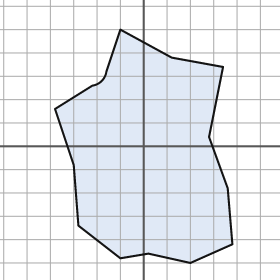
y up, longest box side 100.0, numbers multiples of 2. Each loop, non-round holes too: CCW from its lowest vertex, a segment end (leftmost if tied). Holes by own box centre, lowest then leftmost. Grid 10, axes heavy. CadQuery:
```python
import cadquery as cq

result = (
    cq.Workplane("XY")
    .moveTo(20.0, -50.0)
    .lineTo(38.0, -42.0)
    .lineTo(36.0, -18.0)
    .lineTo(28.0, 4.0)
    .lineTo(34.0, 34.0)
    .lineTo(12.0, 38.0)
    .lineTo(-10.0, 50.0)
    .lineTo(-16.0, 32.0)
    .threePointArc((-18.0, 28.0), (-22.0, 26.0))
    .lineTo(-38.0, 16.0)
    .lineTo(-30.0, -8.0)
    .lineTo(-28.0, -34.0)
    .lineTo(-10.0, -48.0)
    .lineTo(2.0, -46.0)
    .close()
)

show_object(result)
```